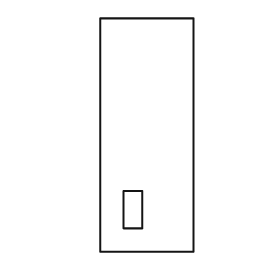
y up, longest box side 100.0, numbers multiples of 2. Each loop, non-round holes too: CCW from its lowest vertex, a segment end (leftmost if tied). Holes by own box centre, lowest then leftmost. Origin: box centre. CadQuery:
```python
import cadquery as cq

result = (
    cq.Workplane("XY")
    .moveTo(-20.0, -50.0)
    .lineTo(20.0, -50.0)
    .lineTo(20.0, 50.0)
    .lineTo(-20.0, 50.0)
    .close()
    .moveTo(-10.0, -40.0)
    .lineTo(-2.0, -40.0)
    .lineTo(-2.0, -24.0)
    .lineTo(-10.0, -24.0)
    .close()
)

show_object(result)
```